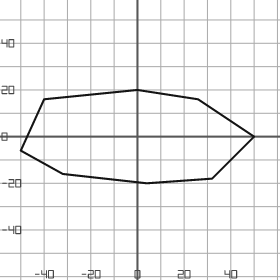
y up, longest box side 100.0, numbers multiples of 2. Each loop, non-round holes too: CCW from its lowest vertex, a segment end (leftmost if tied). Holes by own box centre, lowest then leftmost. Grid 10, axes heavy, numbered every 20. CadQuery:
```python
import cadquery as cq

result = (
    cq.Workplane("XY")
    .moveTo(4.0, -20.0)
    .lineTo(32.0, -18.0)
    .lineTo(50.0, 0.0)
    .lineTo(26.0, 16.0)
    .lineTo(0.0, 20.0)
    .lineTo(-40.0, 16.0)
    .lineTo(-50.0, -6.0)
    .lineTo(-32.0, -16.0)
    .close()
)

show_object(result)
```